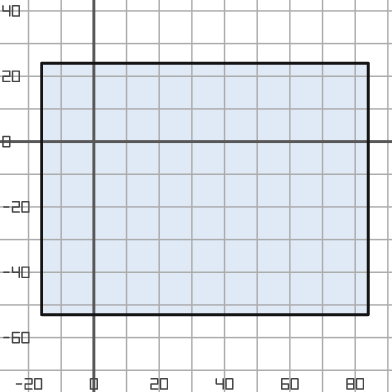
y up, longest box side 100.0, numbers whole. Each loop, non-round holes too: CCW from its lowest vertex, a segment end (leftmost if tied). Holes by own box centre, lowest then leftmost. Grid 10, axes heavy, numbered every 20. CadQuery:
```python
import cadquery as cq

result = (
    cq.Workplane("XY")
    .moveTo(-16.0, -53.0)
    .lineTo(84.0, -53.0)
    .lineTo(84.0, 24.0)
    .lineTo(-16.0, 24.0)
    .close()
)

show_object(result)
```